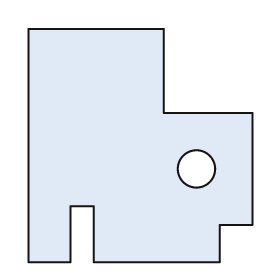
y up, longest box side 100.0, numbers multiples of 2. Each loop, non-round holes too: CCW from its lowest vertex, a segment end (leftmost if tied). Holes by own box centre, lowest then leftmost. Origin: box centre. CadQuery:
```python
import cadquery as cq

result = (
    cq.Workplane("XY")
    .moveTo(-48.0, -50.0)
    .lineTo(-30.0, -50.0)
    .lineTo(-30.0, -26.0)
    .lineTo(-20.0, -26.0)
    .lineTo(-20.0, -50.0)
    .lineTo(34.0, -50.0)
    .lineTo(34.0, -34.0)
    .lineTo(48.0, -34.0)
    .lineTo(48.0, 14.0)
    .lineTo(10.0, 14.0)
    .lineTo(10.0, 50.0)
    .lineTo(-48.0, 50.0)
    .close()
    .moveTo(24.0, -10.0)
    .circle(8.0)
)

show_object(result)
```